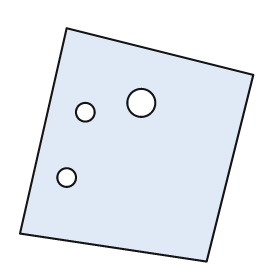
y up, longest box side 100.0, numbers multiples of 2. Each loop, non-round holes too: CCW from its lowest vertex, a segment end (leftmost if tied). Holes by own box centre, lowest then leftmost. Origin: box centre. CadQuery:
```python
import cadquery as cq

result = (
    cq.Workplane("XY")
    .moveTo(30.0, -50.0)
    .lineTo(50.0, 30.0)
    .lineTo(-30.0, 50.0)
    .lineTo(-50.0, -38.0)
    .close()
    .moveTo(-30.0, -14.0)
    .circle(4.0)
    .moveTo(-22.0, 14.0)
    .circle(4.0)
    .moveTo(2.0, 18.0)
    .circle(6.0)
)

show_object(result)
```